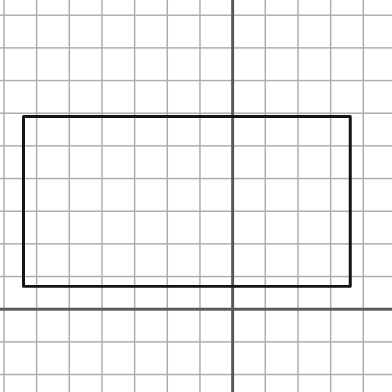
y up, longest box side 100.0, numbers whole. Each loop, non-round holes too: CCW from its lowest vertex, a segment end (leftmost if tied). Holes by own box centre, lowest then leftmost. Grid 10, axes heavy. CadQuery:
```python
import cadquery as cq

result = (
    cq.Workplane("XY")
    .moveTo(-64.0, 7.0)
    .lineTo(36.0, 7.0)
    .lineTo(36.0, 59.0)
    .lineTo(-64.0, 59.0)
    .close()
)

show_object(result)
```